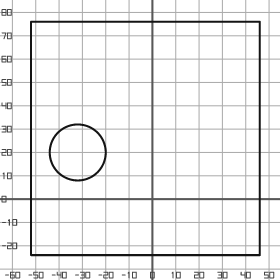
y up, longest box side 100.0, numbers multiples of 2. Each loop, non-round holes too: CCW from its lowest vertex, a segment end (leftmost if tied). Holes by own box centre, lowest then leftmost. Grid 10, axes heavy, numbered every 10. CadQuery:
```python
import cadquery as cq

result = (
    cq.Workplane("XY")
    .moveTo(-52.0, -24.0)
    .lineTo(46.0, -24.0)
    .lineTo(46.0, 76.0)
    .lineTo(-52.0, 76.0)
    .close()
    .moveTo(-32.0, 20.0)
    .circle(12.0)
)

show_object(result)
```